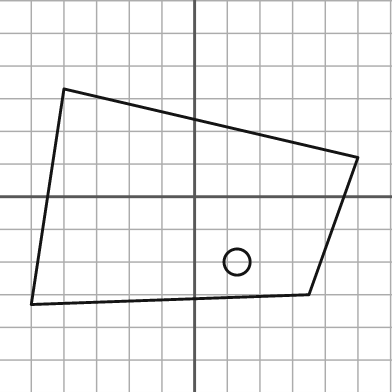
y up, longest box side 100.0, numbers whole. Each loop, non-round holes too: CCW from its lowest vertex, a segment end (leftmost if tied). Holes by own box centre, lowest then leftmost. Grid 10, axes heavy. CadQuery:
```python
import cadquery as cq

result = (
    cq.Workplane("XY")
    .moveTo(-50.0, -33.0)
    .lineTo(35.0, -30.0)
    .lineTo(50.0, 12.0)
    .lineTo(-40.0, 33.0)
    .close()
    .moveTo(13.0, -20.0)
    .circle(4.0)
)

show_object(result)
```